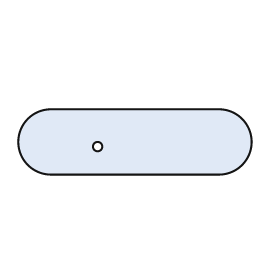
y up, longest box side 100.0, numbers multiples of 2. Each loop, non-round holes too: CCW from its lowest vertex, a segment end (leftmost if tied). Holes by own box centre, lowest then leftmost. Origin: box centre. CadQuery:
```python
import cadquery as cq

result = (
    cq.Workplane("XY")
    .moveTo(-36.0, -14.0)
    .lineTo(36.0, -14.0)
    .threePointArc((50.0, 0.0), (36.0, 14.0))
    .lineTo(-36.0, 14.0)
    .threePointArc((-50.0, 0.0), (-36.0, -14.0))
    .close()
    .moveTo(-16.0, -2.0)
    .circle(2.0)
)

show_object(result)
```